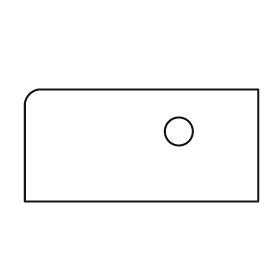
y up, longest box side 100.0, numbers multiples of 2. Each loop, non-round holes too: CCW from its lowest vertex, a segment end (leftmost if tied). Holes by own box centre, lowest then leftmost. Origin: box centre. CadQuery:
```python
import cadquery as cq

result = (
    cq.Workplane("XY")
    .moveTo(-50.0, -24.0)
    .lineTo(50.0, -24.0)
    .lineTo(50.0, 24.0)
    .lineTo(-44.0, 24.0)
    .threePointArc((-48.0, 22.0), (-50.0, 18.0))
    .close()
    .moveTo(16.0, 6.0)
    .circle(6.0)
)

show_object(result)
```